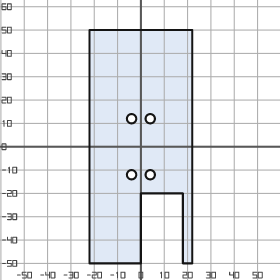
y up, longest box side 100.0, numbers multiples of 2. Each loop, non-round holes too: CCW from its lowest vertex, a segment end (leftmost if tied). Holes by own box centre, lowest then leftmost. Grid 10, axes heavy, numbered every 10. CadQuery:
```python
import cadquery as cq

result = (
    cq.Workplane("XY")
    .moveTo(-22.0, -50.0)
    .lineTo(0.0, -50.0)
    .lineTo(0.0, -20.0)
    .lineTo(18.0, -20.0)
    .lineTo(18.0, -50.0)
    .lineTo(22.0, -50.0)
    .lineTo(22.0, 50.0)
    .lineTo(-22.0, 50.0)
    .close()
    .moveTo(-4.0, -12.0)
    .circle(2.0)
    .moveTo(4.0, -12.0)
    .circle(2.0)
    .moveTo(-4.0, 12.0)
    .circle(2.0)
    .moveTo(4.0, 12.0)
    .circle(2.0)
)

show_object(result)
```